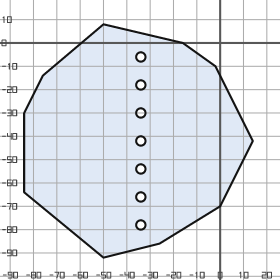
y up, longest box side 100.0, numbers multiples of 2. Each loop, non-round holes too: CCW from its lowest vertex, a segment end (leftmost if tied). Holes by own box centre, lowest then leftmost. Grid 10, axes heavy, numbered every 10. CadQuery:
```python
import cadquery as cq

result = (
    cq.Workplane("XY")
    .moveTo(-50.0, -92.0)
    .lineTo(-26.0, -86.0)
    .lineTo(0.0, -70.0)
    .lineTo(14.0, -42.0)
    .lineTo(-2.0, -10.0)
    .lineTo(-16.0, 0.0)
    .lineTo(-50.0, 8.0)
    .lineTo(-76.0, -14.0)
    .lineTo(-84.0, -30.0)
    .lineTo(-84.0, -64.0)
    .close()
    .moveTo(-34.0, -78.0)
    .circle(2.0)
    .moveTo(-34.0, -66.0)
    .circle(2.0)
    .moveTo(-34.0, -54.0)
    .circle(2.0)
    .moveTo(-34.0, -42.0)
    .circle(2.0)
    .moveTo(-34.0, -30.0)
    .circle(2.0)
    .moveTo(-34.0, -18.0)
    .circle(2.0)
    .moveTo(-34.0, -6.0)
    .circle(2.0)
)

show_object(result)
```